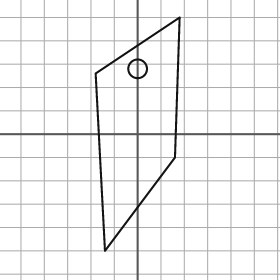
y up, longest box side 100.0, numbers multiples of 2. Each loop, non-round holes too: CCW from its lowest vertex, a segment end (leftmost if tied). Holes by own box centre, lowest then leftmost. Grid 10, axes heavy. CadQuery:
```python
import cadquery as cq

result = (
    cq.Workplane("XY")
    .moveTo(-14.0, -50.0)
    .lineTo(16.0, -10.0)
    .lineTo(18.0, 50.0)
    .lineTo(-18.0, 26.0)
    .close()
    .moveTo(0.0, 28.0)
    .circle(4.0)
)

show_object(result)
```